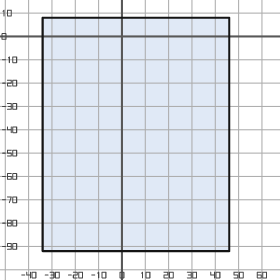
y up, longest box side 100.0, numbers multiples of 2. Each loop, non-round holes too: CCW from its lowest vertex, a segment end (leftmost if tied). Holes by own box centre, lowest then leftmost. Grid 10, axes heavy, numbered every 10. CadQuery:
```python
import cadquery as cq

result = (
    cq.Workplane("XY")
    .moveTo(-34.0, -92.0)
    .lineTo(46.0, -92.0)
    .lineTo(46.0, 8.0)
    .lineTo(-34.0, 8.0)
    .close()
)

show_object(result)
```